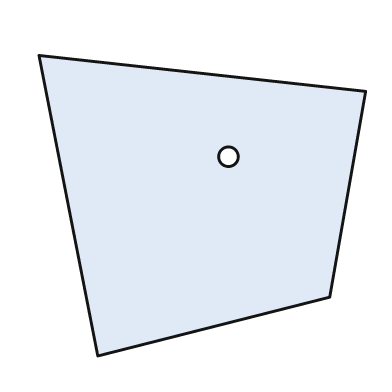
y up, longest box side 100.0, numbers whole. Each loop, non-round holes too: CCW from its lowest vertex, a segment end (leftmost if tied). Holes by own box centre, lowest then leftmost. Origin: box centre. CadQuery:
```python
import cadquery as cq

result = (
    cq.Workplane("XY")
    .moveTo(-32.0, -46.0)
    .lineTo(39.0, -28.0)
    .lineTo(50.0, 35.0)
    .lineTo(-50.0, 46.0)
    .close()
    .moveTo(8.0, 15.0)
    .circle(3.0)
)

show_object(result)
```